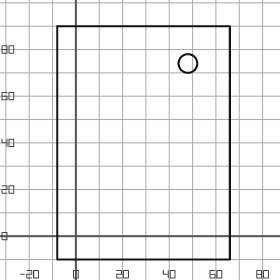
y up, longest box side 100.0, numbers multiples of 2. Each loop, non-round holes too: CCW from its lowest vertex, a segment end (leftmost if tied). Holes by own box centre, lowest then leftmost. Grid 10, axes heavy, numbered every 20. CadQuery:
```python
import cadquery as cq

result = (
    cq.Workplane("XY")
    .moveTo(-8.0, -10.0)
    .lineTo(66.0, -10.0)
    .lineTo(66.0, 90.0)
    .lineTo(-8.0, 90.0)
    .close()
    .moveTo(48.0, 74.0)
    .circle(4.0)
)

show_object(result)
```